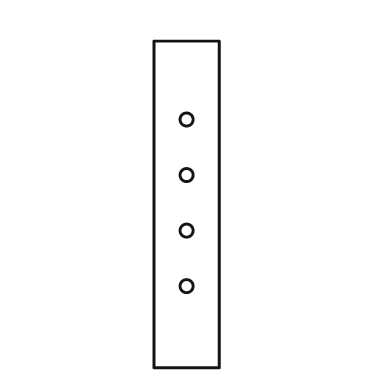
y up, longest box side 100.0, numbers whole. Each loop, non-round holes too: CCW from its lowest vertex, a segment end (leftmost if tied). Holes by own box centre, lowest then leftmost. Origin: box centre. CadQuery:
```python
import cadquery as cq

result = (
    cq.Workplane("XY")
    .moveTo(-10.0, -50.0)
    .lineTo(10.0, -50.0)
    .lineTo(10.0, 50.0)
    .lineTo(-10.0, 50.0)
    .close()
    .moveTo(0.0, -25.0)
    .circle(2.0)
    .moveTo(0.0, -8.0)
    .circle(2.0)
    .moveTo(0.0, 9.0)
    .circle(2.0)
    .moveTo(0.0, 26.0)
    .circle(2.0)
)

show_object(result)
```